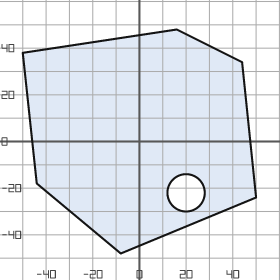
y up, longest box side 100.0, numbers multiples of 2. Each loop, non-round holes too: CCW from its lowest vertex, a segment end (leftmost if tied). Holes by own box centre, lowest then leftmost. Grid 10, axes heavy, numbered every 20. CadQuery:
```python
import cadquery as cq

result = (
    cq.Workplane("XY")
    .moveTo(-8.0, -48.0)
    .lineTo(50.0, -24.0)
    .lineTo(44.0, 34.0)
    .lineTo(16.0, 48.0)
    .lineTo(-50.0, 38.0)
    .lineTo(-44.0, -18.0)
    .close()
    .moveTo(20.0, -22.0)
    .circle(8.0)
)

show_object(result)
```